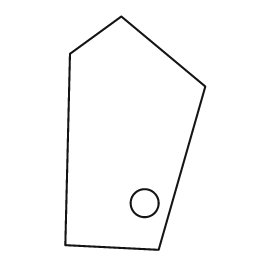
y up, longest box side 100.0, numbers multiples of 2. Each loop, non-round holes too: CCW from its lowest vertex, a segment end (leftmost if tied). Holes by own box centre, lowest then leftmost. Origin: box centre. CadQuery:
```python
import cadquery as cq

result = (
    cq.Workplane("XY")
    .moveTo(10.0, -50.0)
    .lineTo(30.0, 20.0)
    .lineTo(-6.0, 50.0)
    .lineTo(-28.0, 34.0)
    .lineTo(-30.0, -48.0)
    .close()
    .moveTo(4.0, -30.0)
    .circle(6.0)
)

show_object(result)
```